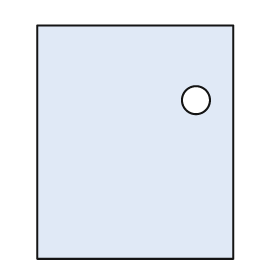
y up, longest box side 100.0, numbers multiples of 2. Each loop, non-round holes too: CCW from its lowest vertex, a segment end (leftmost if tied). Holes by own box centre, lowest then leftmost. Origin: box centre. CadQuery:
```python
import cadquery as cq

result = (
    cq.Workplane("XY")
    .moveTo(-42.0, -50.0)
    .lineTo(42.0, -50.0)
    .lineTo(42.0, 50.0)
    .lineTo(-42.0, 50.0)
    .close()
    .moveTo(26.0, 18.0)
    .circle(6.0)
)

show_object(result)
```